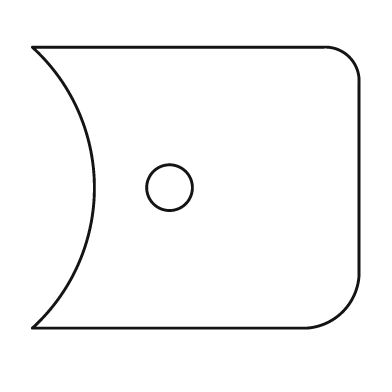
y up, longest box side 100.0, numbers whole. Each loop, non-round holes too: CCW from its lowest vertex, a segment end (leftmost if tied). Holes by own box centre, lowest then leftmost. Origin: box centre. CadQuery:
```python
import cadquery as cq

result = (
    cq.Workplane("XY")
    .moveTo(-50.0, -43.0)
    .lineTo(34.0, -43.0)
    .threePointArc((45.0, -38.0), (50.0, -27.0))
    .lineTo(50.0, 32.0)
    .threePointArc((47.0, 40.0), (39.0, 43.0))
    .lineTo(-50.0, 43.0)
    .threePointArc((-31.0, 0.0), (-50.0, -43.0))
    .close()
    .moveTo(-8.0, 0.0)
    .circle(7.0)
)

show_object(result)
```